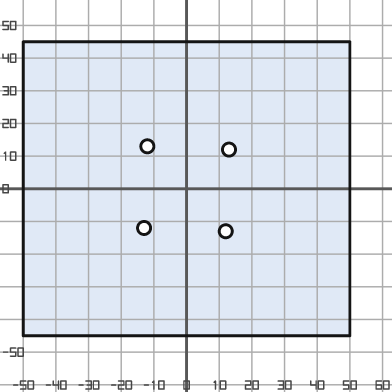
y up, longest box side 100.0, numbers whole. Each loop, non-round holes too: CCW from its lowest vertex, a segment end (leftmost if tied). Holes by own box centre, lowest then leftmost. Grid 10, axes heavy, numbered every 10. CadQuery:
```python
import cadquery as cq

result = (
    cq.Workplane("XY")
    .moveTo(-50.0, -45.0)
    .lineTo(50.0, -45.0)
    .lineTo(50.0, 45.0)
    .lineTo(-50.0, 45.0)
    .close()
    .moveTo(12.0, -13.0)
    .circle(2.0)
    .moveTo(-13.0, -12.0)
    .circle(2.0)
    .moveTo(13.0, 12.0)
    .circle(2.0)
    .moveTo(-12.0, 13.0)
    .circle(2.0)
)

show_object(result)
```